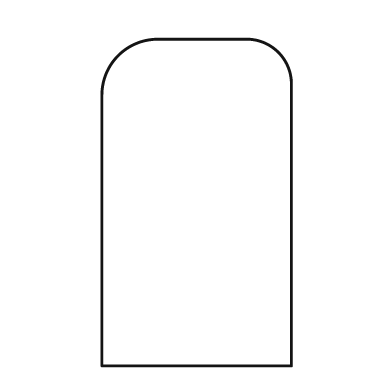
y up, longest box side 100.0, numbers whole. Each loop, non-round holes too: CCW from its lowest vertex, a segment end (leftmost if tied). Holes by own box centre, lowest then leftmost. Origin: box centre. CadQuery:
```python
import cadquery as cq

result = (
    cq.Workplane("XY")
    .moveTo(-29.0, -50.0)
    .lineTo(29.0, -50.0)
    .lineTo(29.0, 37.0)
    .threePointArc((25.0, 46.0), (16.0, 50.0))
    .lineTo(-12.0, 50.0)
    .threePointArc((-24.0, 45.0), (-29.0, 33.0))
    .close()
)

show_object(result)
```